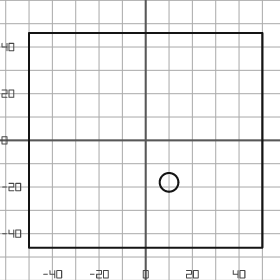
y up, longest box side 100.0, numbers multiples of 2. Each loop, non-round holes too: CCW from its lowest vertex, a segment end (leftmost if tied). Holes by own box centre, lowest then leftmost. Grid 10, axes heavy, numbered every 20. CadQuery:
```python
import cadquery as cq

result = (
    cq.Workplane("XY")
    .moveTo(-50.0, -46.0)
    .lineTo(50.0, -46.0)
    .lineTo(50.0, 46.0)
    .lineTo(-50.0, 46.0)
    .close()
    .moveTo(10.0, -18.0)
    .circle(4.0)
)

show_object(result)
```